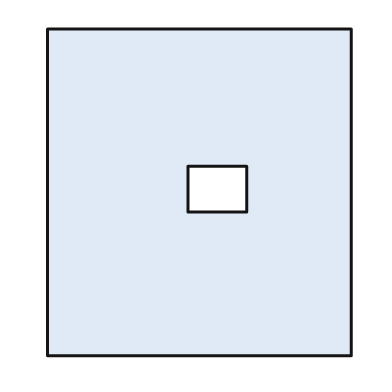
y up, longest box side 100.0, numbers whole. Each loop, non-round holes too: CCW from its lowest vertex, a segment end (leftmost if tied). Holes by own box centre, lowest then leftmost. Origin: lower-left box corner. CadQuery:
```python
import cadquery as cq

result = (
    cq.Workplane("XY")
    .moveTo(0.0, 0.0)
    .lineTo(93.0, 0.0)
    .lineTo(93.0, 100.0)
    .lineTo(0.0, 100.0)
    .close()
    .moveTo(43.0, 44.0)
    .lineTo(61.0, 44.0)
    .lineTo(61.0, 58.0)
    .lineTo(43.0, 58.0)
    .close()
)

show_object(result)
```